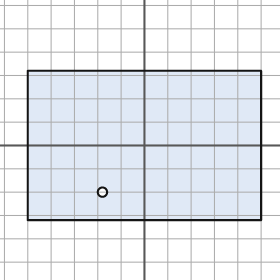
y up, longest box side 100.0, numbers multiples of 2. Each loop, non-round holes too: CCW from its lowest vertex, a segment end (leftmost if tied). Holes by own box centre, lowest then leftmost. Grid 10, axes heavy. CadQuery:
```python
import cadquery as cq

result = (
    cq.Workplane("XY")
    .moveTo(-50.0, -32.0)
    .lineTo(50.0, -32.0)
    .lineTo(50.0, 32.0)
    .lineTo(-50.0, 32.0)
    .close()
    .moveTo(-18.0, -20.0)
    .circle(2.0)
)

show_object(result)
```